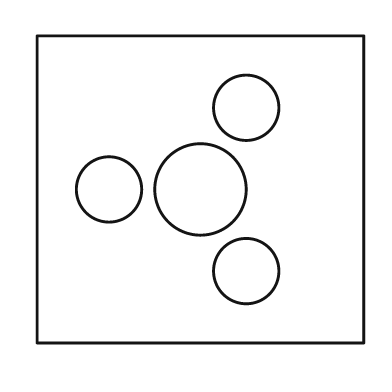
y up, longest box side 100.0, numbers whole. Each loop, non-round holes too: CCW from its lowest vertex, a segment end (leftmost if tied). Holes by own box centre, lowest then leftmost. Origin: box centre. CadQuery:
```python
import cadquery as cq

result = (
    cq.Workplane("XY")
    .moveTo(-50.0, -47.0)
    .lineTo(50.0, -47.0)
    .lineTo(50.0, 47.0)
    .lineTo(-50.0, 47.0)
    .close()
    .moveTo(14.0, -25.0)
    .circle(10.0)
    .moveTo(-28.0, 0.0)
    .circle(10.0)
    .moveTo(0.0, 0.0)
    .circle(14.0)
    .moveTo(14.0, 25.0)
    .circle(10.0)
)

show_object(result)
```